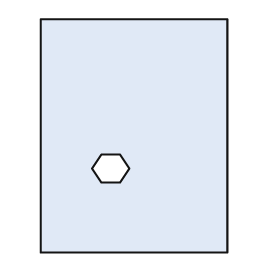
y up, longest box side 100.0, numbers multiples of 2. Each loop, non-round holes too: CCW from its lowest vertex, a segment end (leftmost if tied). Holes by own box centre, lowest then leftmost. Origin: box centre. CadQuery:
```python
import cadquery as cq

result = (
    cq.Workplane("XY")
    .moveTo(-40.0, -50.0)
    .lineTo(40.0, -50.0)
    .lineTo(40.0, 50.0)
    .lineTo(-40.0, 50.0)
    .close()
    .moveTo(-14.0, -20.0)
    .lineTo(-6.0, -20.0)
    .lineTo(-2.0, -14.0)
    .lineTo(-6.0, -8.0)
    .lineTo(-14.0, -8.0)
    .lineTo(-18.0, -14.0)
    .close()
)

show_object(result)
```